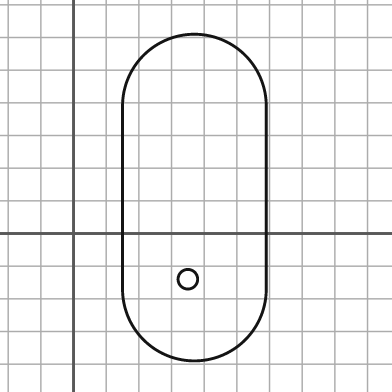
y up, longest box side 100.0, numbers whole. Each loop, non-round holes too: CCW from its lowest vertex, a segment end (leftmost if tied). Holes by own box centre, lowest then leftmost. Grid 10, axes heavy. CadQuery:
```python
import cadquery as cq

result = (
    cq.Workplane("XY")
    .moveTo(15.0, -17.0)
    .threePointArc((37.0, -39.0), (59.0, -17.0))
    .lineTo(59.0, 39.0)
    .threePointArc((37.0, 61.0), (15.0, 39.0))
    .close()
    .moveTo(35.0, -14.0)
    .circle(3.0)
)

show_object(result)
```